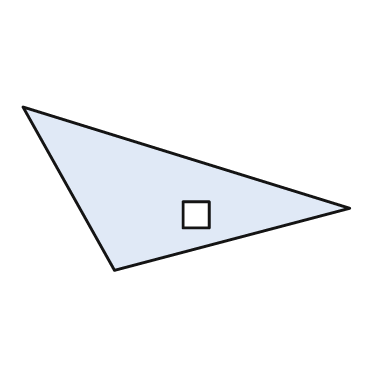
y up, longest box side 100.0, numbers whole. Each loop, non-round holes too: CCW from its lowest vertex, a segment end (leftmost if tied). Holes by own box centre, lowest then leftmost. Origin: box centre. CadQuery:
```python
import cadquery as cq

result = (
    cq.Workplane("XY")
    .moveTo(-22.0, -25.0)
    .lineTo(50.0, -6.0)
    .lineTo(-50.0, 25.0)
    .close()
    .moveTo(-1.0, -12.0)
    .lineTo(7.0, -12.0)
    .lineTo(7.0, -4.0)
    .lineTo(-1.0, -4.0)
    .close()
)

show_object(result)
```